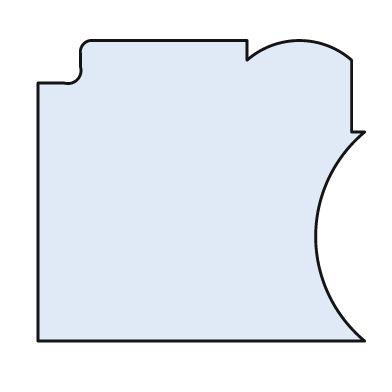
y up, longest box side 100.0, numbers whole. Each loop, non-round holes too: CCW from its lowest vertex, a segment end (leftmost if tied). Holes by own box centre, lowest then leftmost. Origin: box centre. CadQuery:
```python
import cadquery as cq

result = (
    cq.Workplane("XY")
    .moveTo(-50.0, -46.0)
    .lineTo(50.0, -46.0)
    .threePointArc((35.0, -14.0), (50.0, 18.0))
    .lineTo(46.0, 18.0)
    .lineTo(46.0, 40.0)
    .threePointArc((30.0, 46.0), (14.0, 40.0))
    .lineTo(14.0, 46.0)
    .lineTo(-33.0, 46.0)
    .threePointArc((-36.0, 45.0), (-37.0, 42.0))
    .lineTo(-37.0, 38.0)
    .threePointArc((-38.0, 34.0), (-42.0, 33.0))
    .lineTo(-50.0, 33.0)
    .close()
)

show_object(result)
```